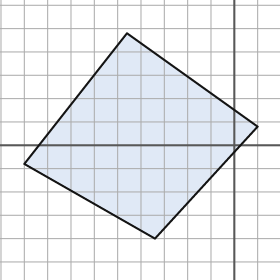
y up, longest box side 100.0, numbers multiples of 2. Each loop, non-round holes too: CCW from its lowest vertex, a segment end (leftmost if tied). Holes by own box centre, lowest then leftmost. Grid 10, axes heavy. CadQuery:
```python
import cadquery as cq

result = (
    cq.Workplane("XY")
    .moveTo(-34.0, -40.0)
    .lineTo(10.0, 8.0)
    .lineTo(-46.0, 48.0)
    .lineTo(-90.0, -8.0)
    .close()
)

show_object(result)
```